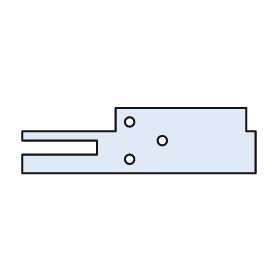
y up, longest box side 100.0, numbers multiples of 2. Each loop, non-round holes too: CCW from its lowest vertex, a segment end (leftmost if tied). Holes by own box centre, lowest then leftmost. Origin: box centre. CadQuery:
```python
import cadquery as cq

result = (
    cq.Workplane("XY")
    .moveTo(-50.0, -14.0)
    .lineTo(50.0, -14.0)
    .lineTo(50.0, 4.0)
    .lineTo(46.0, 4.0)
    .lineTo(46.0, 14.0)
    .lineTo(-10.0, 14.0)
    .lineTo(-10.0, 4.0)
    .lineTo(-50.0, 4.0)
    .lineTo(-50.0, 0.0)
    .lineTo(-18.0, 0.0)
    .lineTo(-18.0, -6.0)
    .lineTo(-50.0, -6.0)
    .close()
    .moveTo(-4.0, -8.0)
    .circle(2.0)
    .moveTo(10.0, 0.0)
    .circle(2.0)
    .moveTo(-4.0, 8.0)
    .circle(2.0)
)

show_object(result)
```